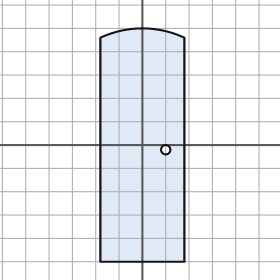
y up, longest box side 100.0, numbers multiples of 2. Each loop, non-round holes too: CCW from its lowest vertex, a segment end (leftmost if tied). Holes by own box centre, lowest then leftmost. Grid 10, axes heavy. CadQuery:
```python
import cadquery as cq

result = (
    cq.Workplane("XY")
    .moveTo(-18.0, -50.0)
    .lineTo(18.0, -50.0)
    .lineTo(18.0, 46.0)
    .threePointArc((0.0, 50.0), (-18.0, 46.0))
    .close()
    .moveTo(10.0, -2.0)
    .circle(2.0)
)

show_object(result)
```